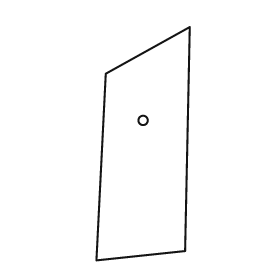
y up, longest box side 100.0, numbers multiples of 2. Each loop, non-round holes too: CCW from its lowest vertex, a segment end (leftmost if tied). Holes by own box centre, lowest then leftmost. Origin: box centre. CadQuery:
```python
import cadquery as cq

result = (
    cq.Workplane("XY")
    .moveTo(-20.0, -50.0)
    .lineTo(18.0, -46.0)
    .lineTo(20.0, 50.0)
    .lineTo(-16.0, 30.0)
    .close()
    .moveTo(0.0, 10.0)
    .circle(2.0)
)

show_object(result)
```